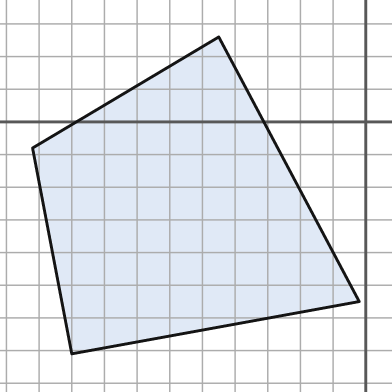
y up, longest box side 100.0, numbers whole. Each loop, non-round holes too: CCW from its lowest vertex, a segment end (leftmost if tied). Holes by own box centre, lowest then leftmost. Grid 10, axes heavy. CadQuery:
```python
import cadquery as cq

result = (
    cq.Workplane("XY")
    .moveTo(-90.0, -71.0)
    .lineTo(-2.0, -55.0)
    .lineTo(-45.0, 26.0)
    .lineTo(-102.0, -8.0)
    .close()
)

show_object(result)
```